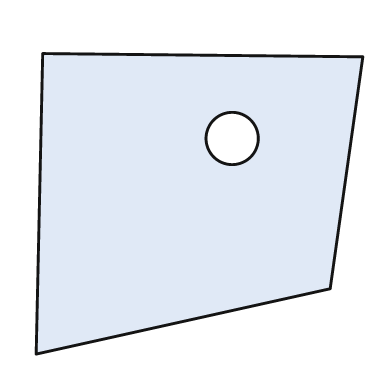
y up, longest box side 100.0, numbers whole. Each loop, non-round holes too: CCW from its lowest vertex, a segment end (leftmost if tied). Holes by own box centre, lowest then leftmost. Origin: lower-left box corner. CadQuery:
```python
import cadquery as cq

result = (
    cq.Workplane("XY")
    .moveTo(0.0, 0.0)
    .lineTo(90.0, 20.0)
    .lineTo(100.0, 91.0)
    .lineTo(2.0, 92.0)
    .close()
    .moveTo(60.0, 66.0)
    .circle(8.0)
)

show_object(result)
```